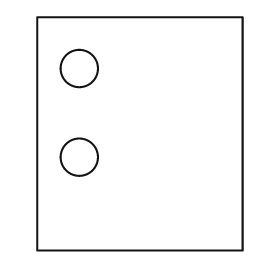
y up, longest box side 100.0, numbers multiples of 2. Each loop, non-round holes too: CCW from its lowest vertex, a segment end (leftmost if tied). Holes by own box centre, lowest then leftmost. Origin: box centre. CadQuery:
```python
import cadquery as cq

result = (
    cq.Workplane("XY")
    .moveTo(-44.0, -50.0)
    .lineTo(44.0, -50.0)
    .lineTo(44.0, 50.0)
    .lineTo(-44.0, 50.0)
    .close()
    .moveTo(-26.0, -10.0)
    .circle(8.0)
    .moveTo(-26.0, 28.0)
    .circle(8.0)
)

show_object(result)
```